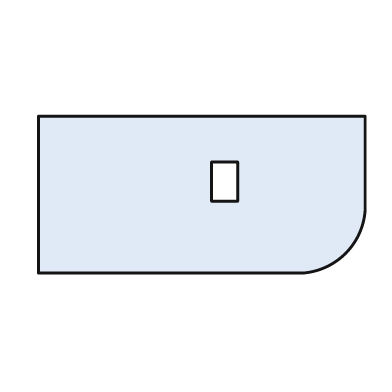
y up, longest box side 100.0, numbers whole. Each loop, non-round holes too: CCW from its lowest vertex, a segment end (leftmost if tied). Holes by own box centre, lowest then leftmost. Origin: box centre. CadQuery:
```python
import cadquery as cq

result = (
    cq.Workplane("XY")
    .moveTo(-50.0, -24.0)
    .lineTo(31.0, -24.0)
    .threePointArc((44.0, -18.0), (50.0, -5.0))
    .lineTo(50.0, 24.0)
    .lineTo(-50.0, 24.0)
    .close()
    .moveTo(3.0, -2.0)
    .lineTo(11.0, -2.0)
    .lineTo(11.0, 10.0)
    .lineTo(3.0, 10.0)
    .close()
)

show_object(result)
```